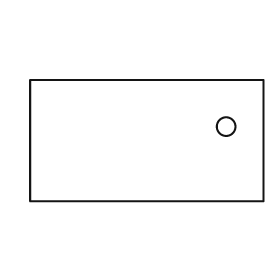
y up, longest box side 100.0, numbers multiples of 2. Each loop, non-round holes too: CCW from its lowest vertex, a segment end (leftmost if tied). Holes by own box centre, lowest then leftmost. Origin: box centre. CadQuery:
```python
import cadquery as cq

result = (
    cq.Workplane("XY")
    .moveTo(-50.0, -26.0)
    .lineTo(50.0, -26.0)
    .lineTo(50.0, 26.0)
    .lineTo(-50.0, 26.0)
    .close()
    .moveTo(34.0, 6.0)
    .circle(4.0)
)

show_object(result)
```